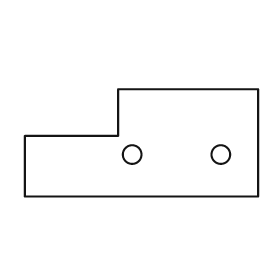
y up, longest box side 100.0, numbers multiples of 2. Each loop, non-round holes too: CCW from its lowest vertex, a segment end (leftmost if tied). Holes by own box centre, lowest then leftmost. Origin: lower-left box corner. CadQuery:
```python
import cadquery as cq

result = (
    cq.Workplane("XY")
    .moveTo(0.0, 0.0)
    .lineTo(100.0, 0.0)
    .lineTo(100.0, 46.0)
    .lineTo(40.0, 46.0)
    .lineTo(40.0, 26.0)
    .lineTo(0.0, 26.0)
    .close()
    .moveTo(46.0, 18.0)
    .circle(4.0)
    .moveTo(84.0, 18.0)
    .circle(4.0)
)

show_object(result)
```